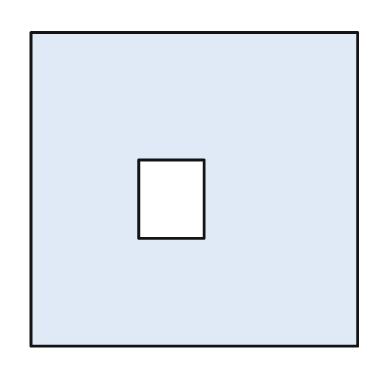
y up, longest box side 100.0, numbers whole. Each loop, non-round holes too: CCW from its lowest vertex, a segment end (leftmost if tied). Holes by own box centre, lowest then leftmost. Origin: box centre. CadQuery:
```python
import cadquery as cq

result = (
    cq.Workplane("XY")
    .moveTo(-50.0, -48.0)
    .lineTo(50.0, -48.0)
    .lineTo(50.0, 48.0)
    .lineTo(-50.0, 48.0)
    .close()
    .moveTo(-17.0, -15.0)
    .lineTo(3.0, -15.0)
    .lineTo(3.0, 9.0)
    .lineTo(-17.0, 9.0)
    .close()
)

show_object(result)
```